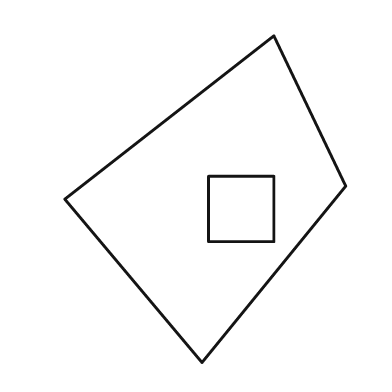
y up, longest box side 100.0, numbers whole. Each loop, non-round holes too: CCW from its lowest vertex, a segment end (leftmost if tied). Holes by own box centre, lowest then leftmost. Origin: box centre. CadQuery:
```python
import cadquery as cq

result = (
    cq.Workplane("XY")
    .moveTo(-1.0, -50.0)
    .lineTo(43.0, 4.0)
    .lineTo(21.0, 50.0)
    .lineTo(-43.0, 0.0)
    .close()
    .moveTo(1.0, -13.0)
    .lineTo(21.0, -13.0)
    .lineTo(21.0, 7.0)
    .lineTo(1.0, 7.0)
    .close()
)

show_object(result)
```